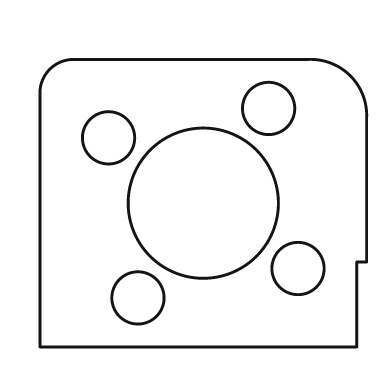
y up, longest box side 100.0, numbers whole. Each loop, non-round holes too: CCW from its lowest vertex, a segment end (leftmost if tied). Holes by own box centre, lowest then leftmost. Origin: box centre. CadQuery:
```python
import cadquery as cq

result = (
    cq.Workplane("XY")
    .moveTo(-50.0, -44.0)
    .lineTo(47.0, -44.0)
    .lineTo(47.0, -18.0)
    .lineTo(50.0, -18.0)
    .lineTo(50.0, 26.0)
    .threePointArc((45.0, 39.0), (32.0, 44.0))
    .lineTo(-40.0, 44.0)
    .threePointArc((-47.0, 41.0), (-50.0, 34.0))
    .close()
    .moveTo(-20.0, -29.0)
    .circle(8.0)
    .moveTo(29.0, -20.0)
    .circle(8.0)
    .moveTo(0.0, 0.0)
    .circle(23.0)
    .moveTo(-29.0, 20.0)
    .circle(8.0)
    .moveTo(20.0, 29.0)
    .circle(8.0)
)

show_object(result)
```